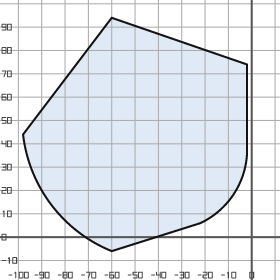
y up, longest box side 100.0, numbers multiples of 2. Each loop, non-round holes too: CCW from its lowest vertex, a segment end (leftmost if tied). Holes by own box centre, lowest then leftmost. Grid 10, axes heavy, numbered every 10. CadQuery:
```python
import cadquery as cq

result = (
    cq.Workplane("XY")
    .moveTo(-60.0, -6.0)
    .lineTo(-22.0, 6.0)
    .threePointArc((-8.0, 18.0), (-2.0, 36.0))
    .lineTo(-2.0, 74.0)
    .lineTo(-60.0, 94.0)
    .lineTo(-98.0, 44.0)
    .threePointArc((-86.0, 14.0), (-60.0, -6.0))
    .close()
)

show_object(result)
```